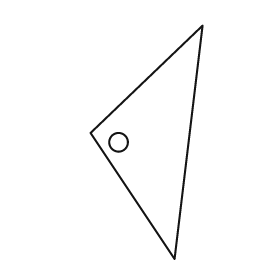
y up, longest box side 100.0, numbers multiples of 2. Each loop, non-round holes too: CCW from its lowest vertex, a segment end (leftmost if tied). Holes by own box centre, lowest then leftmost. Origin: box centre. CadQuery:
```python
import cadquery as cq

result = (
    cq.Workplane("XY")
    .moveTo(12.0, -50.0)
    .lineTo(24.0, 50.0)
    .lineTo(-24.0, 4.0)
    .close()
    .moveTo(-12.0, 0.0)
    .circle(4.0)
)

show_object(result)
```